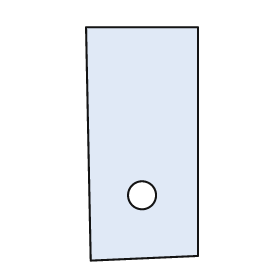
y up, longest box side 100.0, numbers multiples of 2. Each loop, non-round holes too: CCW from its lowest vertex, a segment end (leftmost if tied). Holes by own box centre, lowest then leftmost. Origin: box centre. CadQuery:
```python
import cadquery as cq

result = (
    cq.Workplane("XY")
    .moveTo(-22.0, -50.0)
    .lineTo(24.0, -48.0)
    .lineTo(24.0, 50.0)
    .lineTo(-24.0, 50.0)
    .close()
    .moveTo(0.0, -22.0)
    .circle(6.0)
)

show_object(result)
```